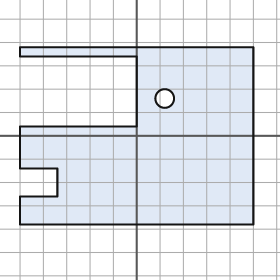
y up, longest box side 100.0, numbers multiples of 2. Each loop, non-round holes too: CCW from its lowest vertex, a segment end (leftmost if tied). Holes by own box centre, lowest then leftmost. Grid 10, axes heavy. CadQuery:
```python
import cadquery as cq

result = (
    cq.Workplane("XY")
    .moveTo(-50.0, -38.0)
    .lineTo(50.0, -38.0)
    .lineTo(50.0, 38.0)
    .lineTo(-50.0, 38.0)
    .lineTo(-50.0, 34.0)
    .lineTo(0.0, 34.0)
    .lineTo(0.0, 4.0)
    .lineTo(-50.0, 4.0)
    .lineTo(-50.0, -14.0)
    .lineTo(-34.0, -14.0)
    .lineTo(-34.0, -26.0)
    .lineTo(-50.0, -26.0)
    .close()
    .moveTo(12.0, 16.0)
    .circle(4.0)
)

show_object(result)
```